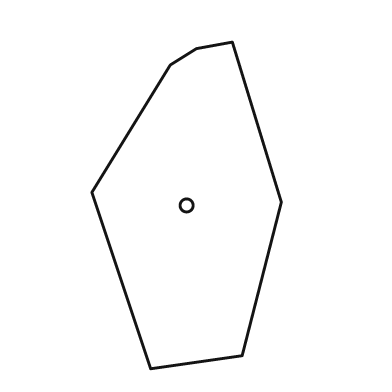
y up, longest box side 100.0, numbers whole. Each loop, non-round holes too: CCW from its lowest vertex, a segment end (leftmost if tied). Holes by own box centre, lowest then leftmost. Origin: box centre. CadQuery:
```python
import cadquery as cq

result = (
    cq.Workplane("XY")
    .moveTo(-11.0, -50.0)
    .lineTo(17.0, -46.0)
    .lineTo(29.0, 1.0)
    .lineTo(14.0, 50.0)
    .lineTo(3.0, 48.0)
    .lineTo(-5.0, 43.0)
    .lineTo(-29.0, 4.0)
    .close()
    .moveTo(0.0, 0.0)
    .circle(2.0)
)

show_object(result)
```